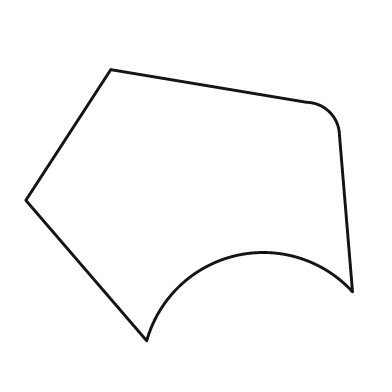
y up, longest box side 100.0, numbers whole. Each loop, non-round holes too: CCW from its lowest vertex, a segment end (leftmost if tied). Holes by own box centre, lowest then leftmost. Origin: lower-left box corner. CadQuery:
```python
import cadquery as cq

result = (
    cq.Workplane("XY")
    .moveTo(37.0, 0.0)
    .threePointArc((64.0, 26.0), (100.0, 15.0))
    .lineTo(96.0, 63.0)
    .threePointArc((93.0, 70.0), (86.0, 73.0))
    .lineTo(26.0, 83.0)
    .lineTo(0.0, 43.0)
    .close()
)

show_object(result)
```